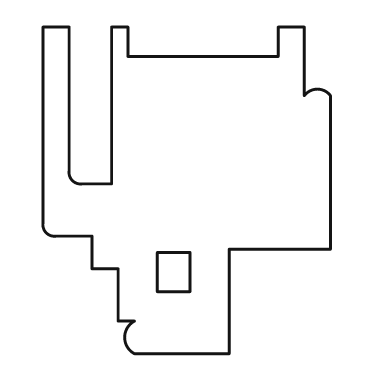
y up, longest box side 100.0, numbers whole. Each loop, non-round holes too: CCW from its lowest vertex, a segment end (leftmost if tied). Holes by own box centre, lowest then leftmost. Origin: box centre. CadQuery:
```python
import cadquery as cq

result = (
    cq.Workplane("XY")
    .moveTo(-16.0, -50.0)
    .lineTo(13.0, -50.0)
    .lineTo(13.0, -18.0)
    .lineTo(44.0, -18.0)
    .lineTo(44.0, 29.0)
    .threePointArc((40.0, 31.0), (36.0, 29.0))
    .lineTo(36.0, 50.0)
    .lineTo(28.0, 50.0)
    .lineTo(28.0, 41.0)
    .lineTo(-18.0, 41.0)
    .lineTo(-18.0, 50.0)
    .lineTo(-23.0, 50.0)
    .lineTo(-23.0, 2.0)
    .lineTo(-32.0, 2.0)
    .threePointArc((-35.0, 3.0), (-36.0, 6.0))
    .lineTo(-36.0, 50.0)
    .lineTo(-44.0, 50.0)
    .lineTo(-44.0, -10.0)
    .threePointArc((-43.0, -13.0), (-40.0, -14.0))
    .lineTo(-29.0, -14.0)
    .lineTo(-29.0, -24.0)
    .lineTo(-21.0, -24.0)
    .lineTo(-21.0, -40.0)
    .lineTo(-16.0, -40.0)
    .threePointArc((-19.0, -45.0), (-16.0, -50.0))
    .close()
    .moveTo(-9.0, -31.0)
    .lineTo(1.0, -31.0)
    .lineTo(1.0, -19.0)
    .lineTo(-9.0, -19.0)
    .close()
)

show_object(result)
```